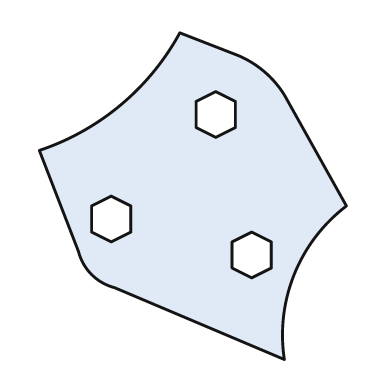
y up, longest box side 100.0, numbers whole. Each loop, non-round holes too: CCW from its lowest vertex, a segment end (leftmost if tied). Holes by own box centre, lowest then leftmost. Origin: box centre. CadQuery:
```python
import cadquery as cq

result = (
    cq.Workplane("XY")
    .moveTo(28.0, -50.0)
    .threePointArc((31.0, -24.0), (47.0, -3.0))
    .lineTo(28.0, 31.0)
    .threePointArc((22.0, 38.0), (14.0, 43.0))
    .lineTo(-4.0, 50.0)
    .threePointArc((-22.0, 28.0), (-47.0, 14.0))
    .lineTo(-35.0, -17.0)
    .threePointArc((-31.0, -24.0), (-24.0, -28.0))
    .close()
    .moveTo(18.0, -25.0)
    .lineTo(24.0, -22.0)
    .lineTo(24.0, -14.0)
    .lineTo(18.0, -11.0)
    .lineTo(12.0, -14.0)
    .lineTo(12.0, -22.0)
    .close()
    .moveTo(-25.0, -14.0)
    .lineTo(-19.0, -11.0)
    .lineTo(-19.0, -3.0)
    .lineTo(-25.0, 0.0)
    .lineTo(-31.0, -3.0)
    .lineTo(-31.0, -11.0)
    .close()
    .moveTo(7.0, 18.0)
    .lineTo(13.0, 21.0)
    .lineTo(13.0, 29.0)
    .lineTo(7.0, 32.0)
    .lineTo(1.0, 29.0)
    .lineTo(1.0, 21.0)
    .close()
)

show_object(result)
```